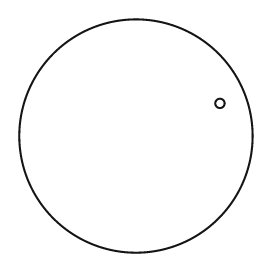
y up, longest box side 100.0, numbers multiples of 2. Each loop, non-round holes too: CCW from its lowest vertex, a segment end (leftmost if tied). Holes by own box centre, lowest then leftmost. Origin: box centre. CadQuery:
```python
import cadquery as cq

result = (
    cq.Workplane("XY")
    .moveTo(0.0, 0.0)
    .circle(50.0)
    .moveTo(36.0, 14.0)
    .circle(2.0)
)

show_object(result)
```